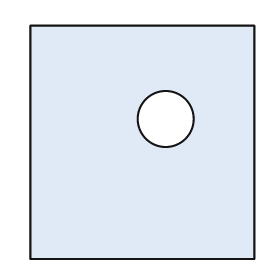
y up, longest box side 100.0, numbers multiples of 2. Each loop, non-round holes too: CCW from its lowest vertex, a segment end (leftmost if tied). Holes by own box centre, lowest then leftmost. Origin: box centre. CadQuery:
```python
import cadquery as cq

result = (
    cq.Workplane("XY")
    .moveTo(-48.0, -50.0)
    .lineTo(48.0, -50.0)
    .lineTo(48.0, 50.0)
    .lineTo(-48.0, 50.0)
    .close()
    .moveTo(10.0, 10.0)
    .circle(12.0)
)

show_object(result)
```